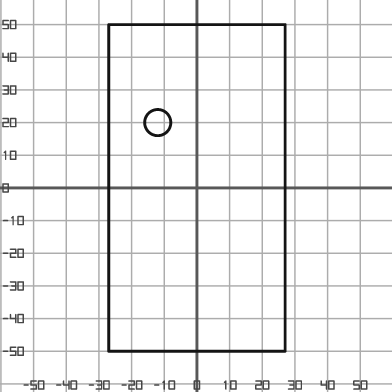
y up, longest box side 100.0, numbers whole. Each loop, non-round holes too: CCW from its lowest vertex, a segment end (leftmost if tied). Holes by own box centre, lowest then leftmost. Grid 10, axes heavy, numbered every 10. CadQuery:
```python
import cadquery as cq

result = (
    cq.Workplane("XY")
    .moveTo(-27.0, -50.0)
    .lineTo(27.0, -50.0)
    .lineTo(27.0, 50.0)
    .lineTo(-27.0, 50.0)
    .close()
    .moveTo(-12.0, 20.0)
    .circle(4.0)
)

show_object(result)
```